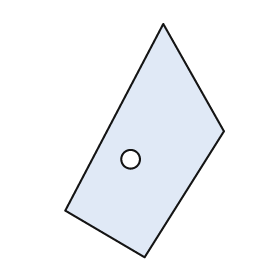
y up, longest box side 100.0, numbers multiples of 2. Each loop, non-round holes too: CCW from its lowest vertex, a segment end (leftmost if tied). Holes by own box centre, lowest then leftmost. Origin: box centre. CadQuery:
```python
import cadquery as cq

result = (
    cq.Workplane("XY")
    .moveTo(0.0, -50.0)
    .lineTo(34.0, 4.0)
    .lineTo(8.0, 50.0)
    .lineTo(-34.0, -30.0)
    .close()
    .moveTo(-6.0, -8.0)
    .circle(4.0)
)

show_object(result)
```